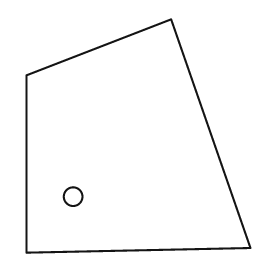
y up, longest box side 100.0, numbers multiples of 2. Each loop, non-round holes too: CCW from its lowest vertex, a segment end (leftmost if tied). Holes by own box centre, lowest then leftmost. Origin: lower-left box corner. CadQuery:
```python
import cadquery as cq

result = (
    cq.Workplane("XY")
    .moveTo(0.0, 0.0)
    .lineTo(96.0, 2.0)
    .lineTo(62.0, 100.0)
    .lineTo(0.0, 76.0)
    .close()
    .moveTo(20.0, 24.0)
    .circle(4.0)
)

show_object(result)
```